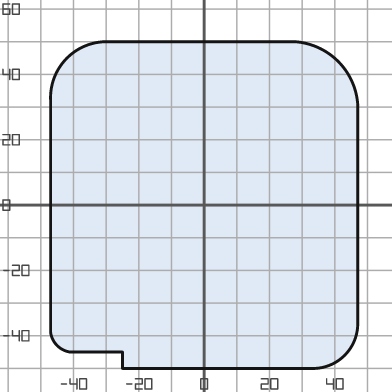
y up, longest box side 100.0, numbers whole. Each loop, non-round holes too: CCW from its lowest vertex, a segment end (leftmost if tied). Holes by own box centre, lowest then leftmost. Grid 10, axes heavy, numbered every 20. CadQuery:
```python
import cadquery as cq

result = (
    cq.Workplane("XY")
    .moveTo(-25.0, -50.0)
    .lineTo(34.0, -50.0)
    .threePointArc((43.0, -46.0), (47.0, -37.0))
    .lineTo(47.0, 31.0)
    .threePointArc((41.0, 44.0), (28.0, 50.0))
    .lineTo(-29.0, 50.0)
    .threePointArc((-42.0, 45.0), (-47.0, 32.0))
    .lineTo(-47.0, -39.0)
    .threePointArc((-45.0, -43.0), (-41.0, -45.0))
    .lineTo(-25.0, -45.0)
    .close()
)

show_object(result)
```